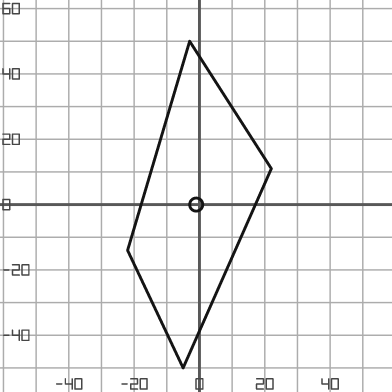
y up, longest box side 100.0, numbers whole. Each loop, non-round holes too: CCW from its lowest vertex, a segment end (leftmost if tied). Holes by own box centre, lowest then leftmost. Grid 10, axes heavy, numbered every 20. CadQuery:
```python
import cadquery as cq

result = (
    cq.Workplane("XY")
    .moveTo(-5.0, -50.0)
    .lineTo(22.0, 11.0)
    .lineTo(-3.0, 50.0)
    .lineTo(-22.0, -14.0)
    .close()
    .moveTo(-1.0, 0.0)
    .circle(2.0)
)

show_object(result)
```